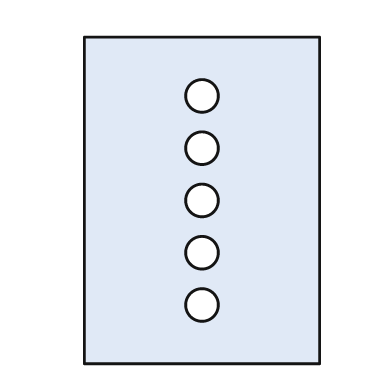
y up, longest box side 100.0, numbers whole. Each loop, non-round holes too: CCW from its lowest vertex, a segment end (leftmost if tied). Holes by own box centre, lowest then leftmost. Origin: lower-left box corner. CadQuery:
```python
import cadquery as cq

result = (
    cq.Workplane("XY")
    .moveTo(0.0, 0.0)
    .lineTo(72.0, 0.0)
    .lineTo(72.0, 100.0)
    .lineTo(0.0, 100.0)
    .close()
    .moveTo(36.0, 18.0)
    .circle(5.0)
    .moveTo(36.0, 34.0)
    .circle(5.0)
    .moveTo(36.0, 50.0)
    .circle(5.0)
    .moveTo(36.0, 66.0)
    .circle(5.0)
    .moveTo(36.0, 82.0)
    .circle(5.0)
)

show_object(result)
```